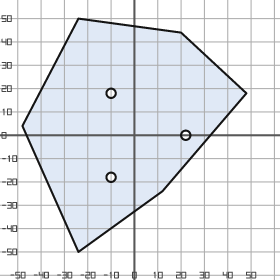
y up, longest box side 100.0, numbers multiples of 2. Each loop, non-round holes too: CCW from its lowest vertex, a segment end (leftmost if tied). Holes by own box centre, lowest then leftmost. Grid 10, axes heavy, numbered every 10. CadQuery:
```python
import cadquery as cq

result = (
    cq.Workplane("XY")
    .moveTo(-24.0, -50.0)
    .lineTo(12.0, -24.0)
    .lineTo(48.0, 18.0)
    .lineTo(20.0, 44.0)
    .lineTo(-24.0, 50.0)
    .lineTo(-48.0, 4.0)
    .close()
    .moveTo(-10.0, -18.0)
    .circle(2.0)
    .moveTo(22.0, 0.0)
    .circle(2.0)
    .moveTo(-10.0, 18.0)
    .circle(2.0)
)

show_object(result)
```